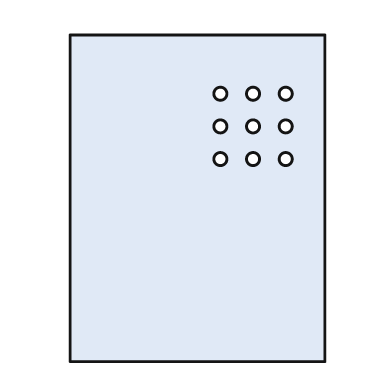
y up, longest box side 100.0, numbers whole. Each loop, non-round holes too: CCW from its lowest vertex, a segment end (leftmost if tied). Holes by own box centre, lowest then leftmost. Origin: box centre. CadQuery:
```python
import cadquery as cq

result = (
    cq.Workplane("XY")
    .moveTo(-39.0, -50.0)
    .lineTo(39.0, -50.0)
    .lineTo(39.0, 50.0)
    .lineTo(-39.0, 50.0)
    .close()
    .moveTo(7.0, 12.0)
    .circle(2.0)
    .moveTo(17.0, 12.0)
    .circle(2.0)
    .moveTo(27.0, 12.0)
    .circle(2.0)
    .moveTo(7.0, 22.0)
    .circle(2.0)
    .moveTo(17.0, 22.0)
    .circle(2.0)
    .moveTo(27.0, 22.0)
    .circle(2.0)
    .moveTo(7.0, 32.0)
    .circle(2.0)
    .moveTo(17.0, 32.0)
    .circle(2.0)
    .moveTo(27.0, 32.0)
    .circle(2.0)
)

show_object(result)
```